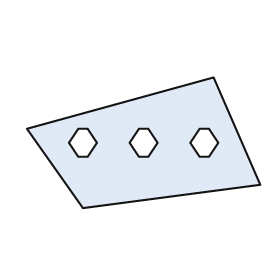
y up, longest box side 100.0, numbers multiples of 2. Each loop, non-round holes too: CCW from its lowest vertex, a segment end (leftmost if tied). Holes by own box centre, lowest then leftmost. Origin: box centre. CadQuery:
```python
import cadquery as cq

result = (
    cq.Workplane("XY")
    .moveTo(-26.0, -28.0)
    .lineTo(50.0, -18.0)
    .lineTo(30.0, 28.0)
    .lineTo(-50.0, 6.0)
    .close()
    .moveTo(-28.0, -6.0)
    .lineTo(-24.0, -6.0)
    .lineTo(-20.0, 0.0)
    .lineTo(-24.0, 6.0)
    .lineTo(-28.0, 6.0)
    .lineTo(-32.0, 0.0)
    .close()
    .moveTo(-2.0, -6.0)
    .lineTo(2.0, -6.0)
    .lineTo(6.0, 0.0)
    .lineTo(2.0, 6.0)
    .lineTo(-2.0, 6.0)
    .lineTo(-6.0, 0.0)
    .close()
    .moveTo(24.0, -6.0)
    .lineTo(28.0, -6.0)
    .lineTo(32.0, 0.0)
    .lineTo(28.0, 6.0)
    .lineTo(24.0, 6.0)
    .lineTo(20.0, 0.0)
    .close()
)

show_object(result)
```